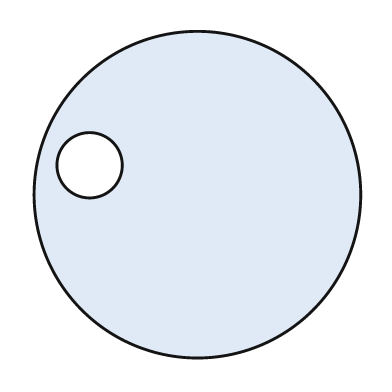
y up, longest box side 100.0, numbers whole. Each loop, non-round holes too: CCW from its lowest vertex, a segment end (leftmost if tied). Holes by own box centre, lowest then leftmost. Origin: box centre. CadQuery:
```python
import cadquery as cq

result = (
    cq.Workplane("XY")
    .moveTo(0.0, 0.0)
    .circle(50.0)
    .moveTo(-33.0, 9.0)
    .circle(10.0)
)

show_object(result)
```